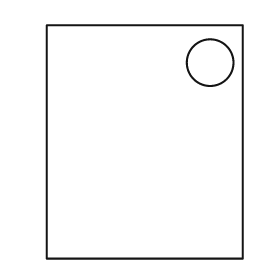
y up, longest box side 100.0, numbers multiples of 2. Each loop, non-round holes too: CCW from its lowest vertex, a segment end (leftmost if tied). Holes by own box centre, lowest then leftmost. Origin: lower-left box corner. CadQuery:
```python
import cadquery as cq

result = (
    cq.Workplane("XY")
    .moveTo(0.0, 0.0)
    .lineTo(84.0, 0.0)
    .lineTo(84.0, 100.0)
    .lineTo(0.0, 100.0)
    .close()
    .moveTo(70.0, 84.0)
    .circle(10.0)
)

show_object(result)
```